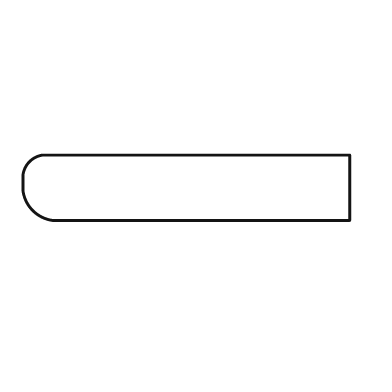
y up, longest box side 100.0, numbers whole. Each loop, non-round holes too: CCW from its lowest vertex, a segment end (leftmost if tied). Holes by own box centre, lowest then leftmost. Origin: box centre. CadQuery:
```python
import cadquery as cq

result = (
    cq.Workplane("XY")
    .moveTo(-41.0, -10.0)
    .lineTo(50.0, -10.0)
    .lineTo(50.0, 10.0)
    .lineTo(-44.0, 10.0)
    .threePointArc((-48.0, 8.0), (-50.0, 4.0))
    .lineTo(-50.0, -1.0)
    .threePointArc((-47.0, -7.0), (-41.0, -10.0))
    .close()
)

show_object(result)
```